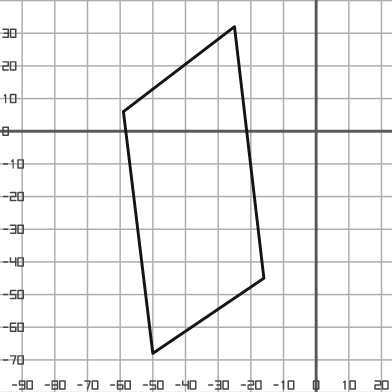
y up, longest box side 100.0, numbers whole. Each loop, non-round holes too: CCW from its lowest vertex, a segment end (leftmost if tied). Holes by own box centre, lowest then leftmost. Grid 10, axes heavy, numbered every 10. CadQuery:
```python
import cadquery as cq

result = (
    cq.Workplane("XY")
    .moveTo(-50.0, -68.0)
    .lineTo(-16.0, -45.0)
    .lineTo(-25.0, 32.0)
    .lineTo(-59.0, 6.0)
    .close()
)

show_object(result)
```